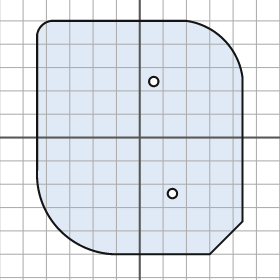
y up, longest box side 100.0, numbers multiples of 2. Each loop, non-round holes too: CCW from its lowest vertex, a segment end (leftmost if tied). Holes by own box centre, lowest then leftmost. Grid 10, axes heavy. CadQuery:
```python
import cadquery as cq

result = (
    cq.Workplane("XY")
    .moveTo(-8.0, -50.0)
    .lineTo(30.0, -50.0)
    .lineTo(44.0, -36.0)
    .lineTo(44.0, 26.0)
    .threePointArc((36.0, 42.0), (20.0, 50.0))
    .lineTo(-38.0, 50.0)
    .threePointArc((-42.0, 48.0), (-44.0, 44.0))
    .lineTo(-44.0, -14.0)
    .threePointArc((-34.0, -40.0), (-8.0, -50.0))
    .close()
    .moveTo(14.0, -24.0)
    .circle(2.0)
    .moveTo(6.0, 24.0)
    .circle(2.0)
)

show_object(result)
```